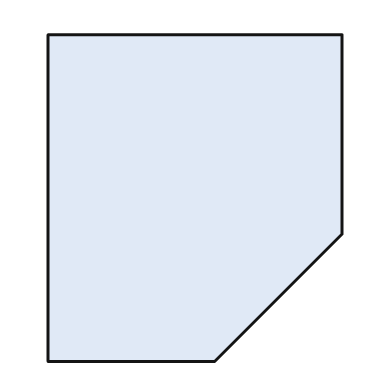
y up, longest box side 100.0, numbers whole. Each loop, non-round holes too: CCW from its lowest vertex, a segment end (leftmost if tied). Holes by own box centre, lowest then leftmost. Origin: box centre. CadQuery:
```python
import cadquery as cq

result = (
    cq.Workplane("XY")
    .moveTo(-45.0, -50.0)
    .lineTo(6.0, -50.0)
    .lineTo(45.0, -11.0)
    .lineTo(45.0, 50.0)
    .lineTo(-45.0, 50.0)
    .close()
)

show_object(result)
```